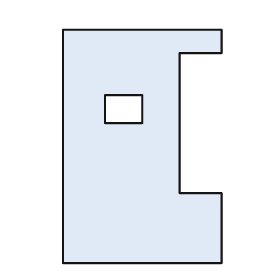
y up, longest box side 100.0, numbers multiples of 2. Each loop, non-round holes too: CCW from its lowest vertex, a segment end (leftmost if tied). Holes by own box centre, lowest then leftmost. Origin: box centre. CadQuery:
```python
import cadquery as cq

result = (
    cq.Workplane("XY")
    .moveTo(-34.0, -50.0)
    .lineTo(34.0, -50.0)
    .lineTo(34.0, -20.0)
    .lineTo(16.0, -20.0)
    .lineTo(16.0, 40.0)
    .lineTo(34.0, 40.0)
    .lineTo(34.0, 50.0)
    .lineTo(-34.0, 50.0)
    .close()
    .moveTo(-16.0, 10.0)
    .lineTo(0.0, 10.0)
    .lineTo(0.0, 22.0)
    .lineTo(-16.0, 22.0)
    .close()
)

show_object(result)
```